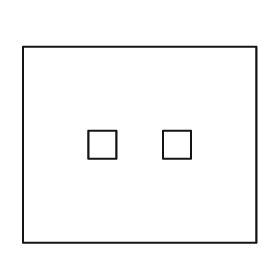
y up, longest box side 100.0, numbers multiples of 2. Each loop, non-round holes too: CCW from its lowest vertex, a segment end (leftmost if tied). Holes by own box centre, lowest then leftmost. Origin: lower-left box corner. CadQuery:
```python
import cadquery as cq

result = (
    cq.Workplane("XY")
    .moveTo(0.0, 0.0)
    .lineTo(100.0, 0.0)
    .lineTo(100.0, 84.0)
    .lineTo(0.0, 84.0)
    .close()
    .moveTo(28.0, 36.0)
    .lineTo(40.0, 36.0)
    .lineTo(40.0, 48.0)
    .lineTo(28.0, 48.0)
    .close()
    .moveTo(60.0, 36.0)
    .lineTo(72.0, 36.0)
    .lineTo(72.0, 48.0)
    .lineTo(60.0, 48.0)
    .close()
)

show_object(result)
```